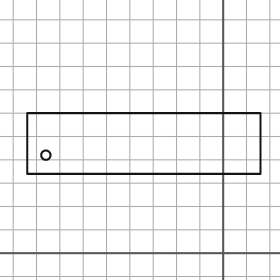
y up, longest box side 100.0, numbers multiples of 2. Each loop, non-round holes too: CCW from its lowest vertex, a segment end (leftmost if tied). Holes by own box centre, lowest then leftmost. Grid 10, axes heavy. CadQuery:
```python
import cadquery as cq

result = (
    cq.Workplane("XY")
    .moveTo(-84.0, 34.0)
    .lineTo(16.0, 34.0)
    .lineTo(16.0, 60.0)
    .lineTo(-84.0, 60.0)
    .close()
    .moveTo(-76.0, 42.0)
    .circle(2.0)
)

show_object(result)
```